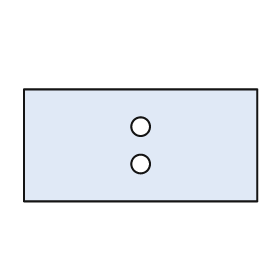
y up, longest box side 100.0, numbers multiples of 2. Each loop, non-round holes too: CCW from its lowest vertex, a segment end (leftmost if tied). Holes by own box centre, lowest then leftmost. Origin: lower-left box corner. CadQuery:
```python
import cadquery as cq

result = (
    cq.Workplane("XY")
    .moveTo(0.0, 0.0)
    .lineTo(100.0, 0.0)
    .lineTo(100.0, 48.0)
    .lineTo(0.0, 48.0)
    .close()
    .moveTo(50.0, 16.0)
    .circle(4.0)
    .moveTo(50.0, 32.0)
    .circle(4.0)
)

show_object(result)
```